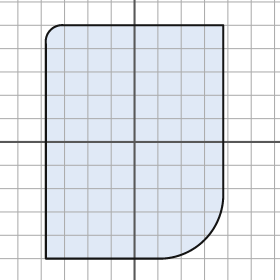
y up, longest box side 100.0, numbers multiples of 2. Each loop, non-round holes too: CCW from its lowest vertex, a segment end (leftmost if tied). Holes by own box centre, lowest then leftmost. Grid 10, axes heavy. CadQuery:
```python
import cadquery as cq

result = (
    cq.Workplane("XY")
    .moveTo(-38.0, -50.0)
    .lineTo(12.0, -50.0)
    .threePointArc((30.0, -42.0), (38.0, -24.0))
    .lineTo(38.0, 50.0)
    .lineTo(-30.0, 50.0)
    .threePointArc((-36.0, 48.0), (-38.0, 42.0))
    .close()
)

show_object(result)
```